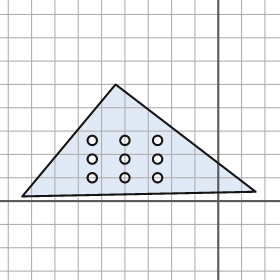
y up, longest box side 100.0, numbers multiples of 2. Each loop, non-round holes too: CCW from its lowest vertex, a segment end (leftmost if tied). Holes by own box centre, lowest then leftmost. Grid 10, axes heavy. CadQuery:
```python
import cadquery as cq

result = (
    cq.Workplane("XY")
    .moveTo(-84.0, 2.0)
    .lineTo(16.0, 4.0)
    .lineTo(-44.0, 50.0)
    .close()
    .moveTo(-54.0, 10.0)
    .circle(2.0)
    .moveTo(-40.0, 10.0)
    .circle(2.0)
    .moveTo(-26.0, 10.0)
    .circle(2.0)
    .moveTo(-54.0, 18.0)
    .circle(2.0)
    .moveTo(-40.0, 18.0)
    .circle(2.0)
    .moveTo(-26.0, 18.0)
    .circle(2.0)
    .moveTo(-54.0, 26.0)
    .circle(2.0)
    .moveTo(-40.0, 26.0)
    .circle(2.0)
    .moveTo(-26.0, 26.0)
    .circle(2.0)
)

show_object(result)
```